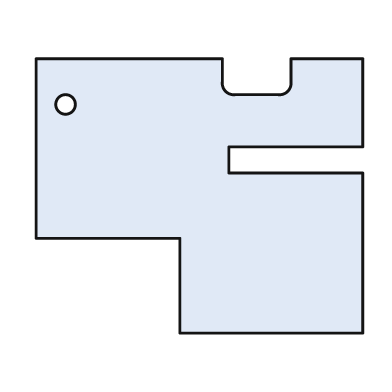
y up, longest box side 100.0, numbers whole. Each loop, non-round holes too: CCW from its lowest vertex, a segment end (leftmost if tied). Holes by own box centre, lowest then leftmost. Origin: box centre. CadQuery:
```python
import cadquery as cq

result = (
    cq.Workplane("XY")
    .moveTo(-6.0, -42.0)
    .lineTo(50.0, -42.0)
    .lineTo(50.0, 7.0)
    .lineTo(9.0, 7.0)
    .lineTo(9.0, 15.0)
    .lineTo(50.0, 15.0)
    .lineTo(50.0, 42.0)
    .lineTo(28.0, 42.0)
    .lineTo(28.0, 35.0)
    .threePointArc((27.0, 32.0), (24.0, 31.0))
    .lineTo(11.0, 31.0)
    .threePointArc((8.0, 32.0), (7.0, 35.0))
    .lineTo(7.0, 42.0)
    .lineTo(-50.0, 42.0)
    .lineTo(-50.0, -13.0)
    .lineTo(-6.0, -13.0)
    .close()
    .moveTo(-41.0, 28.0)
    .circle(3.0)
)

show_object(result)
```